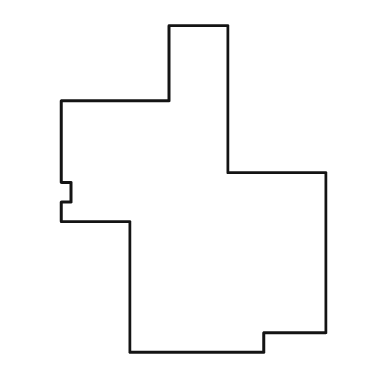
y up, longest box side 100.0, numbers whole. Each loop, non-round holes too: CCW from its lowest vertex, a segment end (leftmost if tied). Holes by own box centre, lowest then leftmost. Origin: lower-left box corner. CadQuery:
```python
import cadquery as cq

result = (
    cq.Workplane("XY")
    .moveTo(21.0, 0.0)
    .lineTo(62.0, 0.0)
    .lineTo(62.0, 6.0)
    .lineTo(81.0, 6.0)
    .lineTo(81.0, 55.0)
    .lineTo(51.0, 55.0)
    .lineTo(51.0, 100.0)
    .lineTo(33.0, 100.0)
    .lineTo(33.0, 77.0)
    .lineTo(0.0, 77.0)
    .lineTo(0.0, 52.0)
    .lineTo(3.0, 52.0)
    .lineTo(3.0, 46.0)
    .lineTo(0.0, 46.0)
    .lineTo(0.0, 40.0)
    .lineTo(21.0, 40.0)
    .close()
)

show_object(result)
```